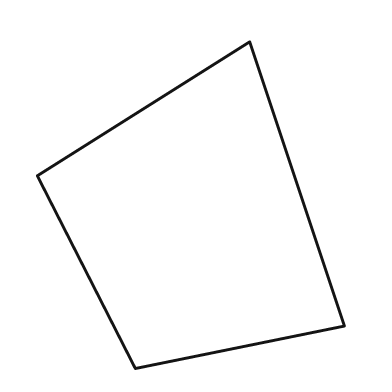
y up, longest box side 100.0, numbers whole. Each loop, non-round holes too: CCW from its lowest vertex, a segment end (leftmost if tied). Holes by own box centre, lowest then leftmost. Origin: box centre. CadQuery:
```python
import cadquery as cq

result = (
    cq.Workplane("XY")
    .moveTo(-17.0, -50.0)
    .lineTo(47.0, -37.0)
    .lineTo(18.0, 50.0)
    .lineTo(-47.0, 9.0)
    .close()
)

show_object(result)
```